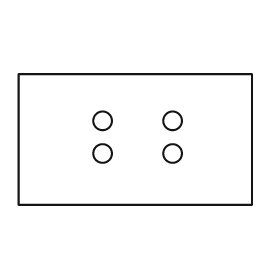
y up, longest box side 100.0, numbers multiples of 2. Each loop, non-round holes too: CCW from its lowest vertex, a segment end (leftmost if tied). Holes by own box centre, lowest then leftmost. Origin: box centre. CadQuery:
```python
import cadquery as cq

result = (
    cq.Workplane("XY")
    .moveTo(-50.0, -28.0)
    .lineTo(50.0, -28.0)
    .lineTo(50.0, 28.0)
    .lineTo(-50.0, 28.0)
    .close()
    .moveTo(-14.0, -6.0)
    .circle(4.0)
    .moveTo(16.0, -6.0)
    .circle(4.0)
    .moveTo(-14.0, 8.0)
    .circle(4.0)
    .moveTo(16.0, 8.0)
    .circle(4.0)
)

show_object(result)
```